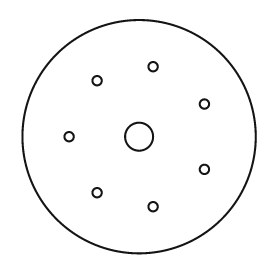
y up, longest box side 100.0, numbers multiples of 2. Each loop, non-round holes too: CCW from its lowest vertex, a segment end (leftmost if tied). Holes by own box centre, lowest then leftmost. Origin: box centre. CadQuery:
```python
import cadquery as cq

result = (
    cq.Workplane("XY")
    .moveTo(0.0, 0.0)
    .circle(50.0)
    .moveTo(6.0, -30.0)
    .circle(2.0)
    .moveTo(-18.0, -24.0)
    .circle(2.0)
    .moveTo(28.0, -14.0)
    .circle(2.0)
    .moveTo(-30.0, 0.0)
    .circle(2.0)
    .moveTo(0.0, 0.0)
    .circle(6.0)
    .moveTo(28.0, 14.0)
    .circle(2.0)
    .moveTo(-18.0, 24.0)
    .circle(2.0)
    .moveTo(6.0, 30.0)
    .circle(2.0)
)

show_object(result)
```